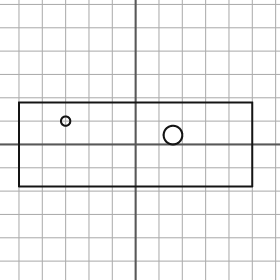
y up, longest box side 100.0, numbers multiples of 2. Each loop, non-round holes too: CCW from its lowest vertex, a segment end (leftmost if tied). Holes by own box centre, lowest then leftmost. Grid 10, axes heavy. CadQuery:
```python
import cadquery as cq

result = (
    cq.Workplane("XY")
    .moveTo(-50.0, -18.0)
    .lineTo(50.0, -18.0)
    .lineTo(50.0, 18.0)
    .lineTo(-50.0, 18.0)
    .close()
    .moveTo(16.0, 4.0)
    .circle(4.0)
    .moveTo(-30.0, 10.0)
    .circle(2.0)
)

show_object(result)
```